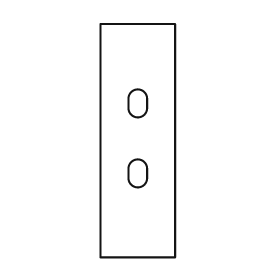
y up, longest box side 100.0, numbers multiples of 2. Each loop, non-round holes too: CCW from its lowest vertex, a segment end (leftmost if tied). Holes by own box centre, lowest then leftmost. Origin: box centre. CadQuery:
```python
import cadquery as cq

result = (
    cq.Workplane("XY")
    .moveTo(-16.0, -50.0)
    .lineTo(16.0, -50.0)
    .lineTo(16.0, 50.0)
    .lineTo(-16.0, 50.0)
    .close()
    .moveTo(-4.0, -16.0)
    .threePointArc((0.0, -20.0), (4.0, -16.0))
    .lineTo(4.0, -12.0)
    .threePointArc((0.0, -8.0), (-4.0, -12.0))
    .close()
    .moveTo(-4.0, 14.0)
    .threePointArc((0.0, 10.0), (4.0, 14.0))
    .lineTo(4.0, 18.0)
    .threePointArc((0.0, 22.0), (-4.0, 18.0))
    .close()
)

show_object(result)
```